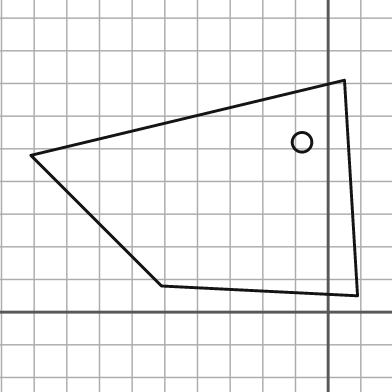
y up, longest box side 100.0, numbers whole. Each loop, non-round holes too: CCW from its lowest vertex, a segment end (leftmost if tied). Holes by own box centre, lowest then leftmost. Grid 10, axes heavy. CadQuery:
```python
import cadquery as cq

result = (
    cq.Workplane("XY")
    .moveTo(9.0, 5.0)
    .lineTo(5.0, 71.0)
    .lineTo(-91.0, 48.0)
    .lineTo(-51.0, 8.0)
    .close()
    .moveTo(-8.0, 52.0)
    .circle(3.0)
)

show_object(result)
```